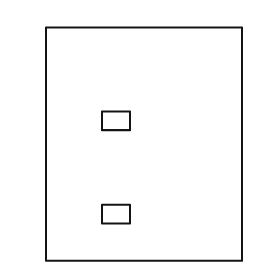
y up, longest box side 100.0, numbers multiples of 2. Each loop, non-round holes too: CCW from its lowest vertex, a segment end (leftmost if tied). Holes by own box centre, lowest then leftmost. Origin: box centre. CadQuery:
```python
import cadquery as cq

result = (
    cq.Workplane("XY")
    .moveTo(-42.0, -50.0)
    .lineTo(42.0, -50.0)
    .lineTo(42.0, 50.0)
    .lineTo(-42.0, 50.0)
    .close()
    .moveTo(-18.0, -34.0)
    .lineTo(-6.0, -34.0)
    .lineTo(-6.0, -26.0)
    .lineTo(-18.0, -26.0)
    .close()
    .moveTo(-18.0, 6.0)
    .lineTo(-6.0, 6.0)
    .lineTo(-6.0, 14.0)
    .lineTo(-18.0, 14.0)
    .close()
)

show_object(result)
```